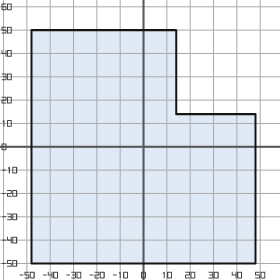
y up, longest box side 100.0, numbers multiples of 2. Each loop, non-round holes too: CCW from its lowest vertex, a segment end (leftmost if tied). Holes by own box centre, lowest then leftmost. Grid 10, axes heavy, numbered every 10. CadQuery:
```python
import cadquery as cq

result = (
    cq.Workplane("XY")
    .moveTo(-48.0, -50.0)
    .lineTo(48.0, -50.0)
    .lineTo(48.0, 14.0)
    .lineTo(14.0, 14.0)
    .lineTo(14.0, 50.0)
    .lineTo(-48.0, 50.0)
    .close()
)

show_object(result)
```